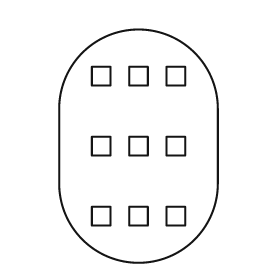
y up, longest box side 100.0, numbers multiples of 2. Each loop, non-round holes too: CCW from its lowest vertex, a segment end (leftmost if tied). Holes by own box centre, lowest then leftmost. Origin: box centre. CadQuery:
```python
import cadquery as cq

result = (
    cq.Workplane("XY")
    .moveTo(-34.0, -16.0)
    .threePointArc((0.0, -50.0), (34.0, -16.0))
    .lineTo(34.0, 16.0)
    .threePointArc((0.0, 50.0), (-34.0, 16.0))
    .close()
    .moveTo(-20.0, -34.0)
    .lineTo(-12.0, -34.0)
    .lineTo(-12.0, -26.0)
    .lineTo(-20.0, -26.0)
    .close()
    .moveTo(-4.0, -34.0)
    .lineTo(4.0, -34.0)
    .lineTo(4.0, -26.0)
    .lineTo(-4.0, -26.0)
    .close()
    .moveTo(12.0, -34.0)
    .lineTo(20.0, -34.0)
    .lineTo(20.0, -26.0)
    .lineTo(12.0, -26.0)
    .close()
    .moveTo(-20.0, -4.0)
    .lineTo(-12.0, -4.0)
    .lineTo(-12.0, 4.0)
    .lineTo(-20.0, 4.0)
    .close()
    .moveTo(-4.0, -4.0)
    .lineTo(4.0, -4.0)
    .lineTo(4.0, 4.0)
    .lineTo(-4.0, 4.0)
    .close()
    .moveTo(12.0, -4.0)
    .lineTo(20.0, -4.0)
    .lineTo(20.0, 4.0)
    .lineTo(12.0, 4.0)
    .close()
    .moveTo(-20.0, 26.0)
    .lineTo(-12.0, 26.0)
    .lineTo(-12.0, 34.0)
    .lineTo(-20.0, 34.0)
    .close()
    .moveTo(-4.0, 26.0)
    .lineTo(4.0, 26.0)
    .lineTo(4.0, 34.0)
    .lineTo(-4.0, 34.0)
    .close()
    .moveTo(12.0, 26.0)
    .lineTo(20.0, 26.0)
    .lineTo(20.0, 34.0)
    .lineTo(12.0, 34.0)
    .close()
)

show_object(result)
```